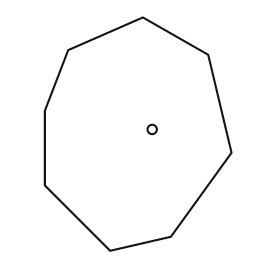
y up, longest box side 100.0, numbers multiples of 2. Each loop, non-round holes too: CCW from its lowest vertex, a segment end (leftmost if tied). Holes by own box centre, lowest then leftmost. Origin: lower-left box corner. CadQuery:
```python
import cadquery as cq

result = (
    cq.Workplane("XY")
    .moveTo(28.0, 0.0)
    .lineTo(54.0, 6.0)
    .lineTo(80.0, 42.0)
    .lineTo(70.0, 84.0)
    .lineTo(42.0, 100.0)
    .lineTo(10.0, 86.0)
    .lineTo(0.0, 60.0)
    .lineTo(0.0, 28.0)
    .close()
    .moveTo(46.0, 52.0)
    .circle(2.0)
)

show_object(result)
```